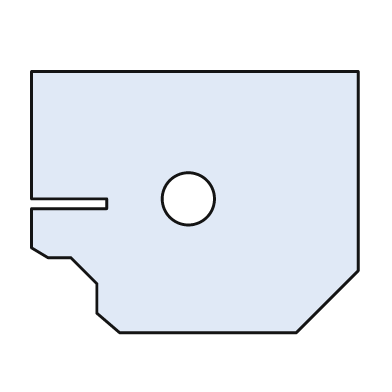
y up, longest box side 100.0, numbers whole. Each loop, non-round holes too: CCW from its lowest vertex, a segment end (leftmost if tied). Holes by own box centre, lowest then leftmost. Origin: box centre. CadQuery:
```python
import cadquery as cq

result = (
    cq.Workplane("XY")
    .moveTo(-23.0, -40.0)
    .lineTo(31.0, -40.0)
    .lineTo(50.0, -21.0)
    .lineTo(50.0, 40.0)
    .lineTo(-50.0, 40.0)
    .lineTo(-50.0, 1.0)
    .lineTo(-27.0, 1.0)
    .lineTo(-27.0, -2.0)
    .lineTo(-50.0, -2.0)
    .lineTo(-50.0, -14.0)
    .lineTo(-45.0, -17.0)
    .lineTo(-38.0, -17.0)
    .lineTo(-30.0, -25.0)
    .lineTo(-30.0, -34.0)
    .close()
    .moveTo(-2.0, 1.0)
    .circle(8.0)
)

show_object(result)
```